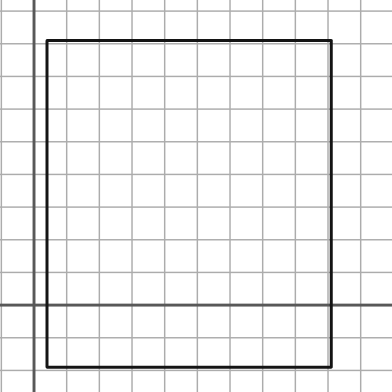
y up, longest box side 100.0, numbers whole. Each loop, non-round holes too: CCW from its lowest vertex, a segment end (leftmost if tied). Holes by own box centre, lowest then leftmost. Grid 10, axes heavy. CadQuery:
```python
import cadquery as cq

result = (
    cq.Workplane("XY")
    .moveTo(4.0, -19.0)
    .lineTo(91.0, -19.0)
    .lineTo(91.0, 81.0)
    .lineTo(4.0, 81.0)
    .close()
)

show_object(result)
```